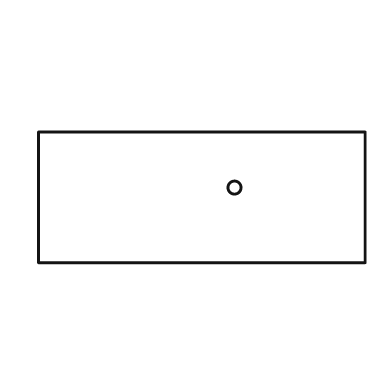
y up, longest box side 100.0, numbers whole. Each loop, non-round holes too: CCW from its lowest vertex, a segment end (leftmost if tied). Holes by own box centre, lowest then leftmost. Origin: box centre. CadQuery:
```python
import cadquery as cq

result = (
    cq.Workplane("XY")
    .moveTo(-50.0, -20.0)
    .lineTo(50.0, -20.0)
    .lineTo(50.0, 20.0)
    .lineTo(-50.0, 20.0)
    .close()
    .moveTo(10.0, 3.0)
    .circle(2.0)
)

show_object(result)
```